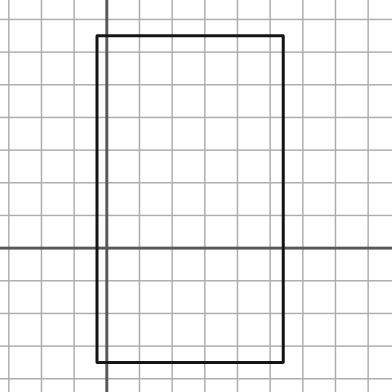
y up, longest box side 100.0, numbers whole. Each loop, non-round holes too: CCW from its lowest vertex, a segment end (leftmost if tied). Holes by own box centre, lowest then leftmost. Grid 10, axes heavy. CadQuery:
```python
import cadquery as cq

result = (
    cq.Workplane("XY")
    .moveTo(-3.0, -35.0)
    .lineTo(54.0, -35.0)
    .lineTo(54.0, 65.0)
    .lineTo(-3.0, 65.0)
    .close()
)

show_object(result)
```